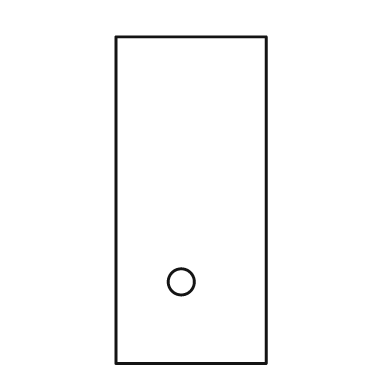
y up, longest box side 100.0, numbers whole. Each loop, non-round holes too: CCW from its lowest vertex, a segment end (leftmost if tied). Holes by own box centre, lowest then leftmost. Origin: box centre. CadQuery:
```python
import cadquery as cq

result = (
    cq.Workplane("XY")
    .moveTo(-23.0, -50.0)
    .lineTo(23.0, -50.0)
    .lineTo(23.0, 50.0)
    .lineTo(-23.0, 50.0)
    .close()
    .moveTo(-3.0, -25.0)
    .circle(4.0)
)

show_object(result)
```